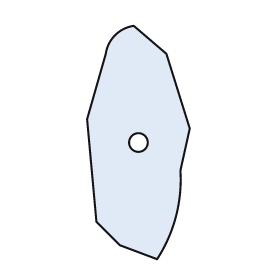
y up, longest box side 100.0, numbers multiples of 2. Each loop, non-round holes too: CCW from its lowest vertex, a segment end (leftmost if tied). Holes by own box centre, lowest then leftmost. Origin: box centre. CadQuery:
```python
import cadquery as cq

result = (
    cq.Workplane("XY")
    .moveTo(8.0, -50.0)
    .threePointArc((16.0, -32.0), (18.0, -12.0))
    .lineTo(22.0, 6.0)
    .lineTo(12.0, 38.0)
    .lineTo(-2.0, 50.0)
    .threePointArc((-10.0, 46.0), (-14.0, 38.0))
    .lineTo(-22.0, 10.0)
    .lineTo(-18.0, -34.0)
    .lineTo(-8.0, -44.0)
    .close()
    .moveTo(0.0, 0.0)
    .circle(4.0)
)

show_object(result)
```